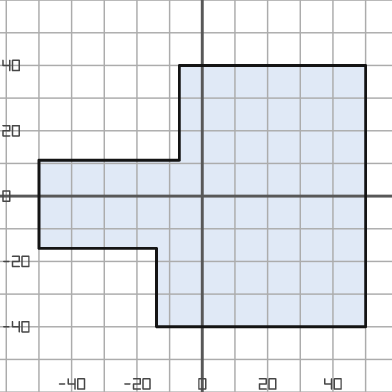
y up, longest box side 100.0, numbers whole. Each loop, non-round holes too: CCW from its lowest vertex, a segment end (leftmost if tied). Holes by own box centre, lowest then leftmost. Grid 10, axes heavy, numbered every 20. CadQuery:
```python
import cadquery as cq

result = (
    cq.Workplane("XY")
    .moveTo(-14.0, -40.0)
    .lineTo(50.0, -40.0)
    .lineTo(50.0, 40.0)
    .lineTo(-7.0, 40.0)
    .lineTo(-7.0, 11.0)
    .lineTo(-50.0, 11.0)
    .lineTo(-50.0, -16.0)
    .lineTo(-14.0, -16.0)
    .close()
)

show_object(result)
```